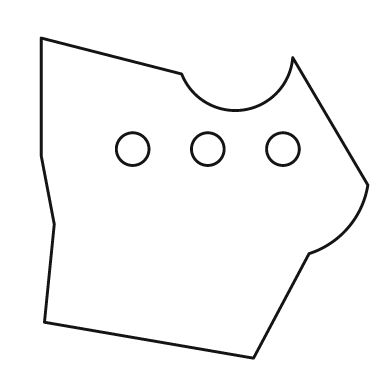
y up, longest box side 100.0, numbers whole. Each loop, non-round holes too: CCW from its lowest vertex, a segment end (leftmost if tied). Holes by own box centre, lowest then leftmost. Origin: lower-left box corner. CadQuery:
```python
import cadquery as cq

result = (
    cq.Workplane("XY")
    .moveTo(65.0, 0.0)
    .lineTo(82.0, 32.0)
    .threePointArc((94.0, 40.0), (100.0, 53.0))
    .lineTo(77.0, 92.0)
    .threePointArc((62.0, 76.0), (43.0, 87.0))
    .lineTo(0.0, 98.0)
    .lineTo(0.0, 62.0)
    .lineTo(4.0, 41.0)
    .lineTo(1.0, 11.0)
    .close()
    .moveTo(28.0, 64.0)
    .circle(5.0)
    .moveTo(51.0, 64.0)
    .circle(5.0)
    .moveTo(74.0, 64.0)
    .circle(5.0)
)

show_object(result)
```